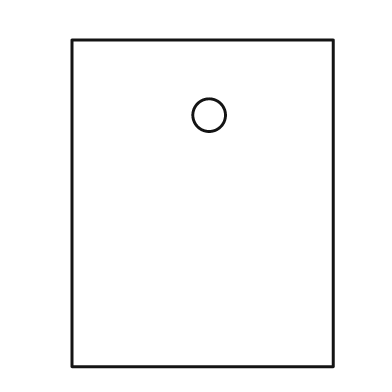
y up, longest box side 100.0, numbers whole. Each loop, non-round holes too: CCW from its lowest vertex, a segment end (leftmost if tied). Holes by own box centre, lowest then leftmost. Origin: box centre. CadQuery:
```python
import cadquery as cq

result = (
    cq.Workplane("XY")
    .moveTo(-40.0, -50.0)
    .lineTo(40.0, -50.0)
    .lineTo(40.0, 50.0)
    .lineTo(-40.0, 50.0)
    .close()
    .moveTo(2.0, 27.0)
    .circle(5.0)
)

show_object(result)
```